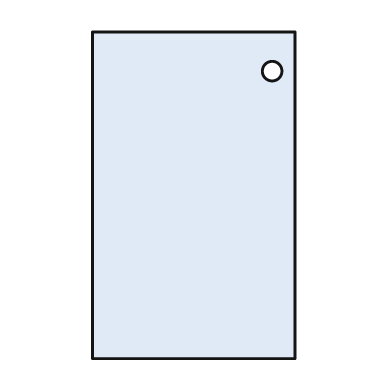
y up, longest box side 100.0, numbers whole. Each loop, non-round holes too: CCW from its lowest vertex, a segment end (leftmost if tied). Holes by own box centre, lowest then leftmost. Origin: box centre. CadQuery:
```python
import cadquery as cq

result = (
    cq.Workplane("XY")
    .moveTo(-31.0, -50.0)
    .lineTo(31.0, -50.0)
    .lineTo(31.0, 50.0)
    .lineTo(-31.0, 50.0)
    .close()
    .moveTo(24.0, 38.0)
    .circle(3.0)
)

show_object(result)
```